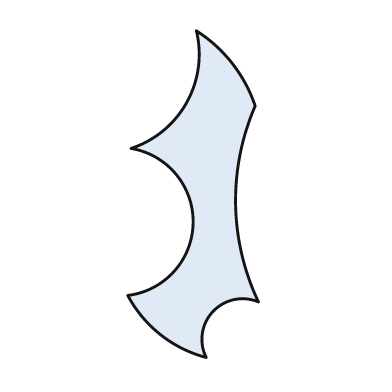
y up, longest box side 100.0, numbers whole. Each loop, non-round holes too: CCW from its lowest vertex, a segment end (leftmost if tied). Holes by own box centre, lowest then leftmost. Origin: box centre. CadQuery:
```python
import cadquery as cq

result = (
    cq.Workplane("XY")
    .moveTo(4.0, -50.0)
    .threePointArc((6.0, -36.0), (20.0, -33.0))
    .threePointArc((13.0, -3.0), (19.0, 27.0))
    .threePointArc((12.0, 40.0), (1.0, 50.0))
    .threePointArc((-2.0, 28.0), (-19.0, 14.0))
    .threePointArc((0.0, -9.0), (-20.0, -31.0))
    .threePointArc((-10.0, -43.0), (4.0, -50.0))
    .close()
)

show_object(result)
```